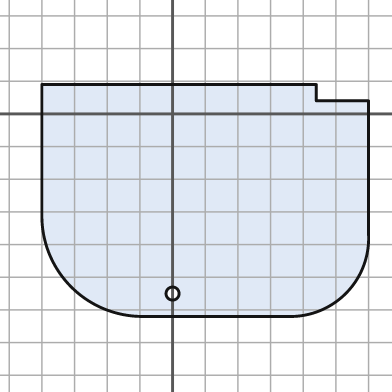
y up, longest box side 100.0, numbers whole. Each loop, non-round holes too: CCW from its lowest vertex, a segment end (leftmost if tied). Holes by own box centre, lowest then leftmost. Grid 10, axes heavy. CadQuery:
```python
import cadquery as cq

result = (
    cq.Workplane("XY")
    .moveTo(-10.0, -62.0)
    .lineTo(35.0, -62.0)
    .threePointArc((53.0, -55.0), (60.0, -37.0))
    .lineTo(60.0, 4.0)
    .lineTo(44.0, 4.0)
    .lineTo(44.0, 9.0)
    .lineTo(-40.0, 9.0)
    .lineTo(-40.0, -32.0)
    .threePointArc((-31.0, -53.0), (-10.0, -62.0))
    .close()
    .moveTo(0.0, -55.0)
    .circle(2.0)
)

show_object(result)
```